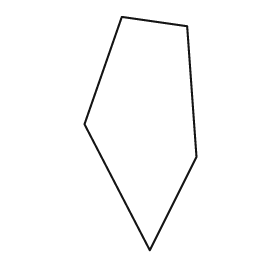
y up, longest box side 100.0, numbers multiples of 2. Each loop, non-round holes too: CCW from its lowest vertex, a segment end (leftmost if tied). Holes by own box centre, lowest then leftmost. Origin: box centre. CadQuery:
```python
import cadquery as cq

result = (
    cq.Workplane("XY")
    .moveTo(4.0, -50.0)
    .lineTo(24.0, -10.0)
    .lineTo(20.0, 46.0)
    .lineTo(-8.0, 50.0)
    .lineTo(-24.0, 4.0)
    .close()
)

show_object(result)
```